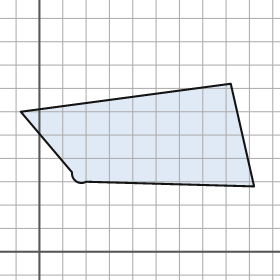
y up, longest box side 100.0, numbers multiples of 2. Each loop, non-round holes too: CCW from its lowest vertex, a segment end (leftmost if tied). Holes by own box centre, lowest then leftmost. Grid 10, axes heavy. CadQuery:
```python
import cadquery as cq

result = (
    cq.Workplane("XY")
    .moveTo(92.0, 28.0)
    .lineTo(82.0, 72.0)
    .lineTo(-8.0, 60.0)
    .lineTo(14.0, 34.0)
    .threePointArc((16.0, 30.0), (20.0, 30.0))
    .close()
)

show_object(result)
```